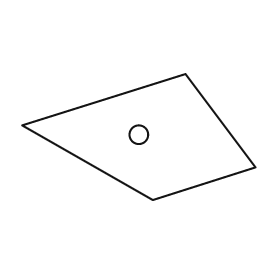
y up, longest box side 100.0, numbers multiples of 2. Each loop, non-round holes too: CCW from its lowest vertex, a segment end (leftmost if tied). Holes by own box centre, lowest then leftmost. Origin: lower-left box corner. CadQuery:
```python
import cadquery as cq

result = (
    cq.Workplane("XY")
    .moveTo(56.0, 0.0)
    .lineTo(100.0, 14.0)
    .lineTo(70.0, 54.0)
    .lineTo(0.0, 32.0)
    .close()
    .moveTo(50.0, 28.0)
    .circle(4.0)
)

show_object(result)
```